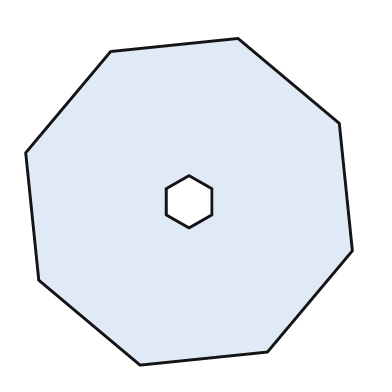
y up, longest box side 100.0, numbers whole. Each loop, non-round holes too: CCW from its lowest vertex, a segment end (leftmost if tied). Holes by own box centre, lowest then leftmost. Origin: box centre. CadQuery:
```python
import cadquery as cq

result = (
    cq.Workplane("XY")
    .moveTo(-15.0, -50.0)
    .lineTo(24.0, -46.0)
    .lineTo(50.0, -15.0)
    .lineTo(46.0, 24.0)
    .lineTo(15.0, 50.0)
    .lineTo(-24.0, 46.0)
    .lineTo(-50.0, 15.0)
    .lineTo(-46.0, -24.0)
    .close()
    .moveTo(0.0, -8.0)
    .lineTo(7.0, -4.0)
    .lineTo(7.0, 4.0)
    .lineTo(0.0, 8.0)
    .lineTo(-7.0, 4.0)
    .lineTo(-7.0, -4.0)
    .close()
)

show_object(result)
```